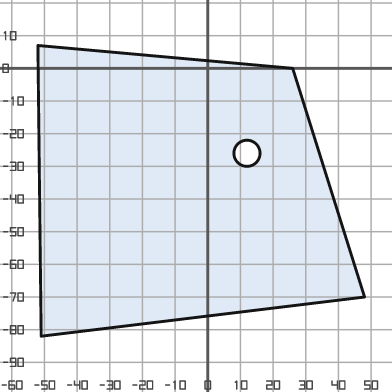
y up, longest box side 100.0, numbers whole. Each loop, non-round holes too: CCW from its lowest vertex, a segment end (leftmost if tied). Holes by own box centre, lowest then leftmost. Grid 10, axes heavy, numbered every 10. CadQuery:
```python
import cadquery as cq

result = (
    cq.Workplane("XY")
    .moveTo(-51.0, -82.0)
    .lineTo(48.0, -70.0)
    .lineTo(26.0, 0.0)
    .lineTo(-52.0, 7.0)
    .close()
    .moveTo(12.0, -26.0)
    .circle(4.0)
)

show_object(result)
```